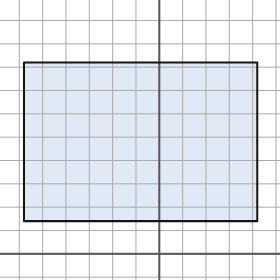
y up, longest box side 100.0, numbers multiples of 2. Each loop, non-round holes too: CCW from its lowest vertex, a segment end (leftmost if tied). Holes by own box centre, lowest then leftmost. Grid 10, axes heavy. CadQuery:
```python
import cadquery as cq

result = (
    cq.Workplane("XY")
    .moveTo(-58.0, 14.0)
    .lineTo(42.0, 14.0)
    .lineTo(42.0, 82.0)
    .lineTo(-58.0, 82.0)
    .close()
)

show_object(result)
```